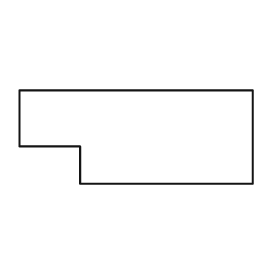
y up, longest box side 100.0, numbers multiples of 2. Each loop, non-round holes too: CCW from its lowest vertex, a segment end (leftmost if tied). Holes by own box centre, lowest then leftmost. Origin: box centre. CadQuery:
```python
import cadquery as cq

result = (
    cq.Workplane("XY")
    .moveTo(-24.0, -20.0)
    .lineTo(50.0, -20.0)
    .lineTo(50.0, 20.0)
    .lineTo(-50.0, 20.0)
    .lineTo(-50.0, -4.0)
    .lineTo(-24.0, -4.0)
    .close()
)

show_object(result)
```